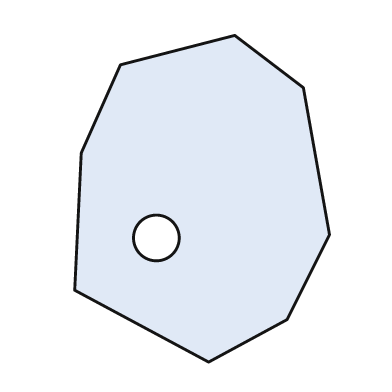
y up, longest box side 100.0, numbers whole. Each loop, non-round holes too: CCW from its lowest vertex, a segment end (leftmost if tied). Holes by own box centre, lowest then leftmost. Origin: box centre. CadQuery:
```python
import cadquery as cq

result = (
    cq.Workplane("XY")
    .moveTo(2.0, -50.0)
    .lineTo(26.0, -37.0)
    .lineTo(39.0, -11.0)
    .lineTo(31.0, 34.0)
    .lineTo(10.0, 50.0)
    .lineTo(-25.0, 41.0)
    .lineTo(-37.0, 14.0)
    .lineTo(-39.0, -28.0)
    .close()
    .moveTo(-14.0, -12.0)
    .circle(7.0)
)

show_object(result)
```